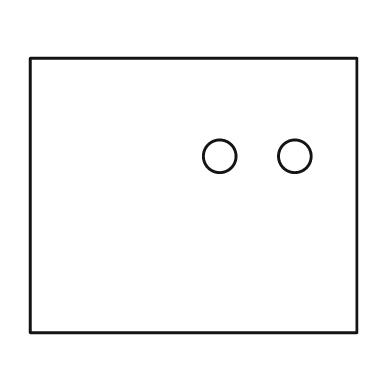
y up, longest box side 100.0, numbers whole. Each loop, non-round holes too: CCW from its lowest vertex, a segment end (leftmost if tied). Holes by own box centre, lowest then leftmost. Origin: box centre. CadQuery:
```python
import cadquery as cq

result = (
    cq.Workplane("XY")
    .moveTo(-50.0, -42.0)
    .lineTo(50.0, -42.0)
    .lineTo(50.0, 42.0)
    .lineTo(-50.0, 42.0)
    .close()
    .moveTo(8.0, 12.0)
    .circle(5.0)
    .moveTo(31.0, 12.0)
    .circle(5.0)
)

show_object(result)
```